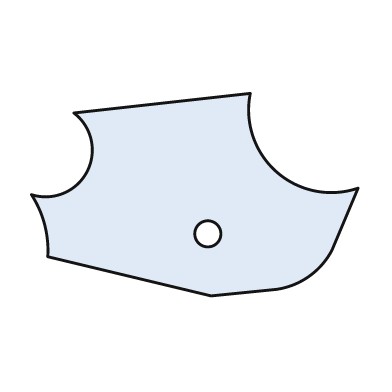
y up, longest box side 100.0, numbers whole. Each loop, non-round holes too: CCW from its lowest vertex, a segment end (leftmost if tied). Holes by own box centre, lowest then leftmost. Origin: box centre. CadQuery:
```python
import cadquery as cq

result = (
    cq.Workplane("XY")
    .moveTo(5.0, -31.0)
    .lineTo(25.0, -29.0)
    .threePointArc((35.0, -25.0), (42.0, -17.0))
    .lineTo(50.0, 2.0)
    .threePointArc((25.0, 7.0), (17.0, 31.0))
    .lineTo(-37.0, 25.0)
    .threePointArc((-33.0, 7.0), (-50.0, 0.0))
    .threePointArc((-46.0, -9.0), (-45.0, -19.0))
    .close()
    .moveTo(4.0, -12.0)
    .circle(4.0)
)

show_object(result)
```